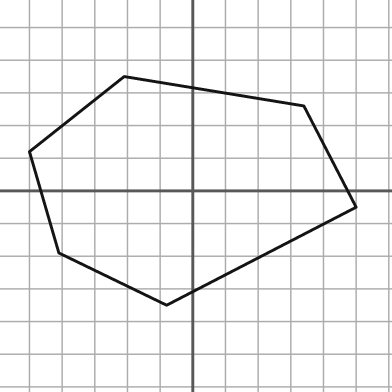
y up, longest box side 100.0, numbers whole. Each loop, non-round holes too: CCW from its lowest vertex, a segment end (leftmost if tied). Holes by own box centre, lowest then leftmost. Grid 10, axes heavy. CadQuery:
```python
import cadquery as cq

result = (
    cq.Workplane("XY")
    .moveTo(-8.0, -35.0)
    .lineTo(50.0, -5.0)
    .lineTo(34.0, 26.0)
    .lineTo(-21.0, 35.0)
    .lineTo(-50.0, 12.0)
    .lineTo(-41.0, -19.0)
    .close()
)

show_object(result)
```